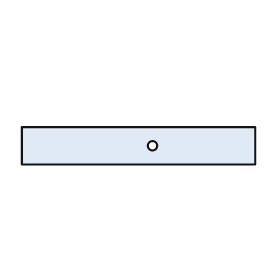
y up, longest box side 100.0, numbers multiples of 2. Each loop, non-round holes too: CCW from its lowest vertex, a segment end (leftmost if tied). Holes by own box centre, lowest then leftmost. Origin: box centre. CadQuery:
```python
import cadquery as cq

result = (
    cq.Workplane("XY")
    .moveTo(-50.0, -8.0)
    .lineTo(50.0, -8.0)
    .lineTo(50.0, 8.0)
    .lineTo(-50.0, 8.0)
    .close()
    .moveTo(6.0, 0.0)
    .circle(2.0)
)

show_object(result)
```